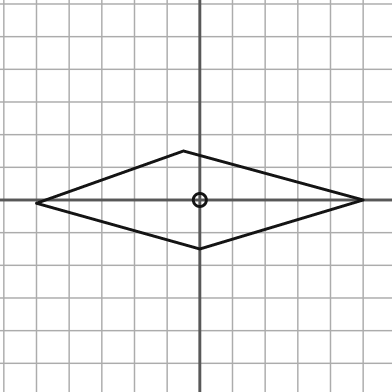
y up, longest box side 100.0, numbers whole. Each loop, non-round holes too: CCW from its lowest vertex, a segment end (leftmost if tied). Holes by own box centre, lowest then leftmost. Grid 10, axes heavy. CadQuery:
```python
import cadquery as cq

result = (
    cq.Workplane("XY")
    .moveTo(0.0, -15.0)
    .lineTo(50.0, 0.0)
    .lineTo(-5.0, 15.0)
    .lineTo(-50.0, -1.0)
    .close()
    .moveTo(0.0, 0.0)
    .circle(2.0)
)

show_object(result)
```